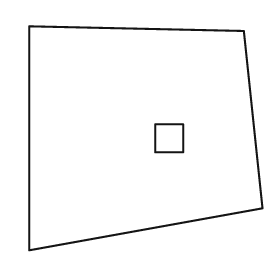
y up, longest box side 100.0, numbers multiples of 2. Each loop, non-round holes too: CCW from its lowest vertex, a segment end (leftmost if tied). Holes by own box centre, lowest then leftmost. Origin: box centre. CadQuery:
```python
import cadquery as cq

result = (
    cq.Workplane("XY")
    .moveTo(-50.0, -48.0)
    .lineTo(50.0, -30.0)
    .lineTo(42.0, 46.0)
    .lineTo(-50.0, 48.0)
    .close()
    .moveTo(4.0, -6.0)
    .lineTo(16.0, -6.0)
    .lineTo(16.0, 6.0)
    .lineTo(4.0, 6.0)
    .close()
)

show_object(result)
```